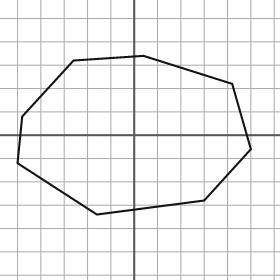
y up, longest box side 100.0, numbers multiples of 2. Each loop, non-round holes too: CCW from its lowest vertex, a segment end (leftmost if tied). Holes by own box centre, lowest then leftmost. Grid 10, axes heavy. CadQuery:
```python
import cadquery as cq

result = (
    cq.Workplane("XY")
    .moveTo(-16.0, -34.0)
    .lineTo(30.0, -28.0)
    .lineTo(50.0, -6.0)
    .lineTo(42.0, 22.0)
    .lineTo(4.0, 34.0)
    .lineTo(-26.0, 32.0)
    .lineTo(-48.0, 8.0)
    .lineTo(-50.0, -12.0)
    .close()
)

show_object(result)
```